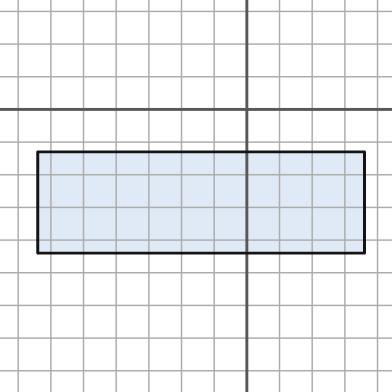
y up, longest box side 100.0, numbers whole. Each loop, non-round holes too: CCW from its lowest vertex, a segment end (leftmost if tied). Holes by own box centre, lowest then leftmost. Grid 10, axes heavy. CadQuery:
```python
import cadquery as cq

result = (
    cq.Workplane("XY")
    .moveTo(-64.0, -44.0)
    .lineTo(36.0, -44.0)
    .lineTo(36.0, -13.0)
    .lineTo(-64.0, -13.0)
    .close()
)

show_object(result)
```